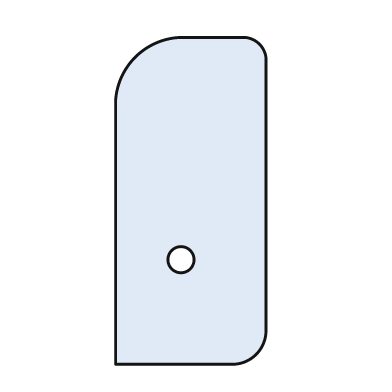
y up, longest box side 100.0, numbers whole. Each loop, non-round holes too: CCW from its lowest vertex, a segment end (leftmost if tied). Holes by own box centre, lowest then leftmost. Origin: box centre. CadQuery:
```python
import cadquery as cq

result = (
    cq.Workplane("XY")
    .moveTo(-23.0, -50.0)
    .lineTo(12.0, -50.0)
    .threePointArc((20.0, -47.0), (23.0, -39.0))
    .lineTo(23.0, 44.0)
    .threePointArc((21.0, 48.0), (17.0, 50.0))
    .lineTo(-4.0, 50.0)
    .threePointArc((-17.0, 44.0), (-23.0, 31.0))
    .close()
    .moveTo(-3.0, -18.0)
    .circle(4.0)
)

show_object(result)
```